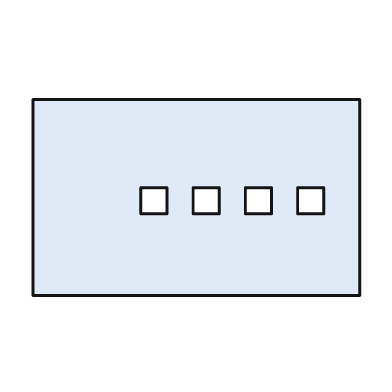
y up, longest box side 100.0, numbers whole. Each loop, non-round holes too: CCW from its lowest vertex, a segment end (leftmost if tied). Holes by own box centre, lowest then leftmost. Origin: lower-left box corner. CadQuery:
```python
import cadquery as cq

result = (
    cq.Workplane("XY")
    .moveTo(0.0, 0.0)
    .lineTo(100.0, 0.0)
    .lineTo(100.0, 60.0)
    .lineTo(0.0, 60.0)
    .close()
    .moveTo(33.0, 25.0)
    .lineTo(41.0, 25.0)
    .lineTo(41.0, 33.0)
    .lineTo(33.0, 33.0)
    .close()
    .moveTo(49.0, 25.0)
    .lineTo(57.0, 25.0)
    .lineTo(57.0, 33.0)
    .lineTo(49.0, 33.0)
    .close()
    .moveTo(65.0, 25.0)
    .lineTo(73.0, 25.0)
    .lineTo(73.0, 33.0)
    .lineTo(65.0, 33.0)
    .close()
    .moveTo(81.0, 25.0)
    .lineTo(89.0, 25.0)
    .lineTo(89.0, 33.0)
    .lineTo(81.0, 33.0)
    .close()
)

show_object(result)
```